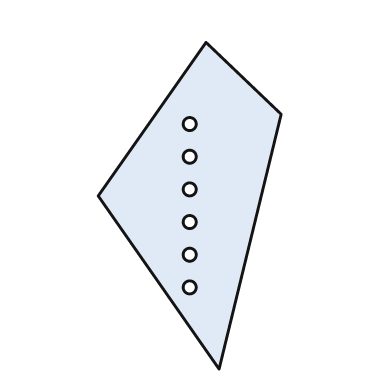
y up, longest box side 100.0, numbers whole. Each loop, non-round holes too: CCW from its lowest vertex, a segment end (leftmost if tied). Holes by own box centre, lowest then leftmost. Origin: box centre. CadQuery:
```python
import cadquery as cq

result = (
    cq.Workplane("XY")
    .moveTo(9.0, -50.0)
    .lineTo(28.0, 28.0)
    .lineTo(5.0, 50.0)
    .lineTo(-28.0, 3.0)
    .close()
    .moveTo(0.0, -25.0)
    .circle(2.0)
    .moveTo(0.0, -15.0)
    .circle(2.0)
    .moveTo(0.0, -5.0)
    .circle(2.0)
    .moveTo(0.0, 5.0)
    .circle(2.0)
    .moveTo(0.0, 15.0)
    .circle(2.0)
    .moveTo(0.0, 25.0)
    .circle(2.0)
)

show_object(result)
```